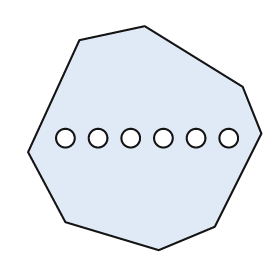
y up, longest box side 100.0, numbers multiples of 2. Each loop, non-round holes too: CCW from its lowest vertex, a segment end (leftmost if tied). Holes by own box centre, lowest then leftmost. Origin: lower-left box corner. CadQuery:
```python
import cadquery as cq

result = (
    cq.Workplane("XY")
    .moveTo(56.0, 0.0)
    .lineTo(80.0, 10.0)
    .lineTo(100.0, 50.0)
    .lineTo(92.0, 70.0)
    .lineTo(50.0, 96.0)
    .lineTo(22.0, 90.0)
    .lineTo(0.0, 42.0)
    .lineTo(16.0, 12.0)
    .close()
    .moveTo(16.0, 48.0)
    .circle(4.0)
    .moveTo(30.0, 48.0)
    .circle(4.0)
    .moveTo(44.0, 48.0)
    .circle(4.0)
    .moveTo(58.0, 48.0)
    .circle(4.0)
    .moveTo(72.0, 48.0)
    .circle(4.0)
    .moveTo(86.0, 48.0)
    .circle(4.0)
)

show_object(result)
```